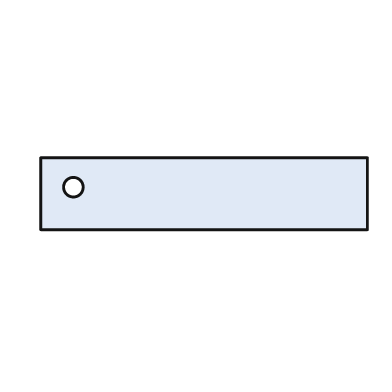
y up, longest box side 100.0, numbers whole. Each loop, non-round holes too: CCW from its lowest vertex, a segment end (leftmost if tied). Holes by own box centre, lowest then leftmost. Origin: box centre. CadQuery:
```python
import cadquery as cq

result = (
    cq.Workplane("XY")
    .moveTo(-50.0, -11.0)
    .lineTo(50.0, -11.0)
    .lineTo(50.0, 11.0)
    .lineTo(-50.0, 11.0)
    .close()
    .moveTo(-40.0, 2.0)
    .circle(3.0)
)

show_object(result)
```